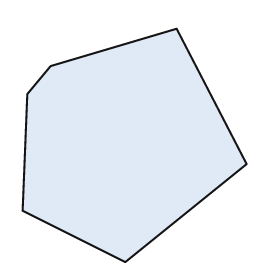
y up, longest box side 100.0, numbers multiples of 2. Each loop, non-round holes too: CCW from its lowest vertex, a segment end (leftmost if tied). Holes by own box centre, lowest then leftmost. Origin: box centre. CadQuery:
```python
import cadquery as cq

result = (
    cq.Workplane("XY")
    .moveTo(-4.0, -50.0)
    .lineTo(48.0, -8.0)
    .lineTo(18.0, 50.0)
    .lineTo(-36.0, 34.0)
    .lineTo(-46.0, 22.0)
    .lineTo(-48.0, -28.0)
    .close()
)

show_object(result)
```